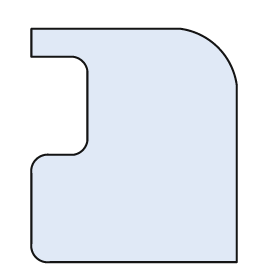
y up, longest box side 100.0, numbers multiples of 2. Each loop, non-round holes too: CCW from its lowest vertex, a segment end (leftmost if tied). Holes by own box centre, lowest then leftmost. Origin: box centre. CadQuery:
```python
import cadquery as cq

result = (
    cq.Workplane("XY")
    .moveTo(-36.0, -50.0)
    .lineTo(44.0, -50.0)
    .lineTo(44.0, 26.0)
    .threePointArc((36.0, 42.0), (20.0, 50.0))
    .lineTo(-44.0, 50.0)
    .lineTo(-44.0, 38.0)
    .lineTo(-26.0, 38.0)
    .threePointArc((-22.0, 36.0), (-20.0, 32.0))
    .lineTo(-20.0, 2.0)
    .threePointArc((-22.0, -2.0), (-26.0, -4.0))
    .lineTo(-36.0, -4.0)
    .threePointArc((-42.0, -6.0), (-44.0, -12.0))
    .lineTo(-44.0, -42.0)
    .threePointArc((-42.0, -48.0), (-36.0, -50.0))
    .close()
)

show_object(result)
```